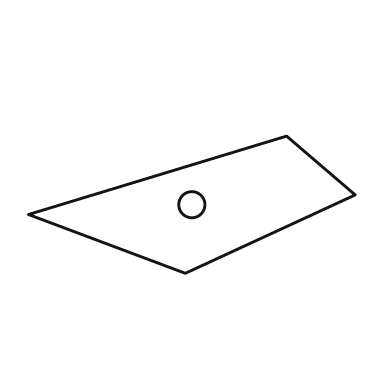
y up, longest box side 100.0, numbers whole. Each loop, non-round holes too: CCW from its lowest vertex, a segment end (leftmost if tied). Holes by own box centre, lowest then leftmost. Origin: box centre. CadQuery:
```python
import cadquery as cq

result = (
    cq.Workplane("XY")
    .moveTo(-2.0, -21.0)
    .lineTo(50.0, 3.0)
    .lineTo(29.0, 21.0)
    .lineTo(-50.0, -3.0)
    .close()
    .moveTo(0.0, 0.0)
    .circle(4.0)
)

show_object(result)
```